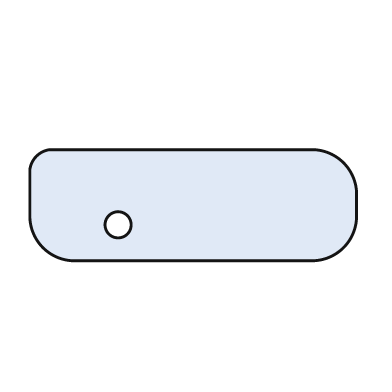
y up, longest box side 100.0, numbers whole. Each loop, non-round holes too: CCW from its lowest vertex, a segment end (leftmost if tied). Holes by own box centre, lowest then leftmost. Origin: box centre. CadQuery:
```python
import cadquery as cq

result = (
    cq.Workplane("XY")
    .moveTo(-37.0, -17.0)
    .lineTo(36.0, -17.0)
    .threePointArc((46.0, -13.0), (50.0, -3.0))
    .lineTo(50.0, 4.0)
    .threePointArc((46.0, 13.0), (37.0, 17.0))
    .lineTo(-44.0, 17.0)
    .threePointArc((-48.0, 15.0), (-50.0, 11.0))
    .lineTo(-50.0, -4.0)
    .threePointArc((-46.0, -13.0), (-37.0, -17.0))
    .close()
    .moveTo(-23.0, -6.0)
    .circle(4.0)
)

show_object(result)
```